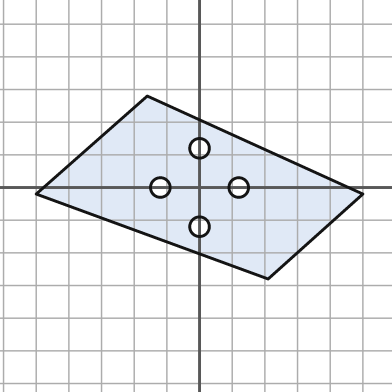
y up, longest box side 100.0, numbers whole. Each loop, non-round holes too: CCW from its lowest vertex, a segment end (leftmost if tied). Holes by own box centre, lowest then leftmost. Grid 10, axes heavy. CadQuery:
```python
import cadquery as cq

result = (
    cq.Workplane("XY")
    .moveTo(21.0, -28.0)
    .lineTo(50.0, -2.0)
    .lineTo(-16.0, 28.0)
    .lineTo(-50.0, -2.0)
    .close()
    .moveTo(0.0, -12.0)
    .circle(3.0)
    .moveTo(-12.0, 0.0)
    .circle(3.0)
    .moveTo(12.0, 0.0)
    .circle(3.0)
    .moveTo(0.0, 12.0)
    .circle(3.0)
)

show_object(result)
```